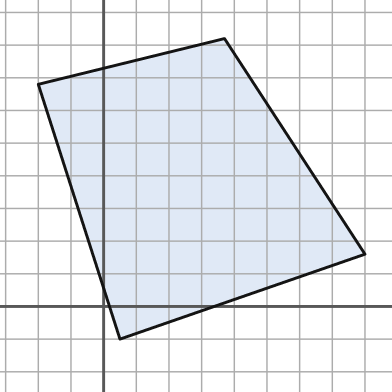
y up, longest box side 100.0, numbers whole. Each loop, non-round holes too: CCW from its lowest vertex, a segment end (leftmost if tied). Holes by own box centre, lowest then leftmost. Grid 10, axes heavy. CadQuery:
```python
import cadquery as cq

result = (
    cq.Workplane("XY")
    .moveTo(5.0, -10.0)
    .lineTo(80.0, 16.0)
    .lineTo(37.0, 82.0)
    .lineTo(-20.0, 68.0)
    .close()
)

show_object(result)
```